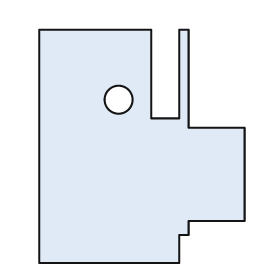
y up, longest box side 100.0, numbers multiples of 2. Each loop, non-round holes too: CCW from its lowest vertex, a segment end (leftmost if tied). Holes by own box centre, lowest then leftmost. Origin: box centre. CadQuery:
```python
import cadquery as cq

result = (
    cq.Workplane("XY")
    .moveTo(-44.0, -50.0)
    .lineTo(16.0, -50.0)
    .lineTo(16.0, -38.0)
    .lineTo(20.0, -38.0)
    .lineTo(20.0, -32.0)
    .lineTo(44.0, -32.0)
    .lineTo(44.0, 8.0)
    .lineTo(20.0, 8.0)
    .lineTo(20.0, 50.0)
    .lineTo(16.0, 50.0)
    .lineTo(16.0, 12.0)
    .lineTo(4.0, 12.0)
    .lineTo(4.0, 50.0)
    .lineTo(-44.0, 50.0)
    .close()
    .moveTo(-10.0, 20.0)
    .circle(6.0)
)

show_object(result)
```